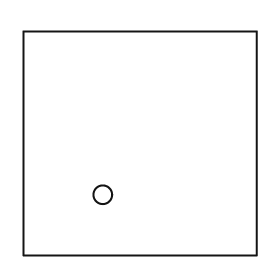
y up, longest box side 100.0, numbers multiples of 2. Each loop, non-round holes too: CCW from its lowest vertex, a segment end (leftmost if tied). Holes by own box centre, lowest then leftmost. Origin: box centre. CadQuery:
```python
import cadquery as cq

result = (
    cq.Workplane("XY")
    .moveTo(-50.0, -48.0)
    .lineTo(50.0, -48.0)
    .lineTo(50.0, 48.0)
    .lineTo(-50.0, 48.0)
    .close()
    .moveTo(-16.0, -22.0)
    .circle(4.0)
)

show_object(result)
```